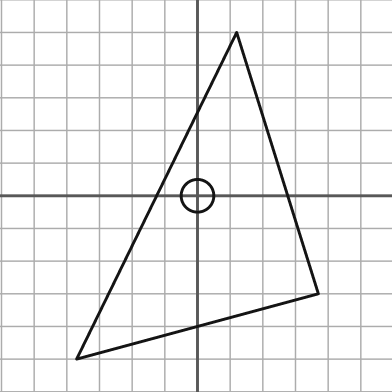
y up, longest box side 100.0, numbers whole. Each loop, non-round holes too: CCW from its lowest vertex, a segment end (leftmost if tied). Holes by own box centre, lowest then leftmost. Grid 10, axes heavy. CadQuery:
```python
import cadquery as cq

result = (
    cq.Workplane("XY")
    .moveTo(-37.0, -50.0)
    .lineTo(37.0, -30.0)
    .lineTo(12.0, 50.0)
    .close()
    .moveTo(0.0, 0.0)
    .circle(5.0)
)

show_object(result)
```